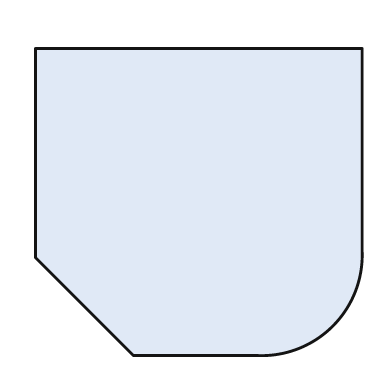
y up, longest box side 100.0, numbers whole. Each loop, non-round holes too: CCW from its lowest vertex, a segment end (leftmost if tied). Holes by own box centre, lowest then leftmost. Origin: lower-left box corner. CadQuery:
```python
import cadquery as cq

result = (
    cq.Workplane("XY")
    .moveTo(30.0, 0.0)
    .lineTo(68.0, 0.0)
    .threePointArc((91.0, 9.0), (100.0, 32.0))
    .lineTo(100.0, 94.0)
    .lineTo(0.0, 94.0)
    .lineTo(0.0, 30.0)
    .close()
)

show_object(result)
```